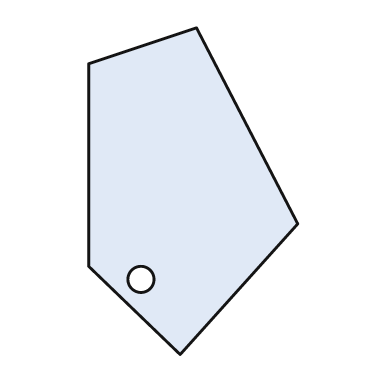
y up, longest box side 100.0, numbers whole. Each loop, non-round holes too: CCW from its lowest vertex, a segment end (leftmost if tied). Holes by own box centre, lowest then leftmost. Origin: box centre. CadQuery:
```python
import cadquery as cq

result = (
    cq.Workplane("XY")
    .moveTo(-4.0, -50.0)
    .lineTo(32.0, -10.0)
    .lineTo(1.0, 50.0)
    .lineTo(-32.0, 39.0)
    .lineTo(-32.0, -23.0)
    .close()
    .moveTo(-16.0, -27.0)
    .circle(4.0)
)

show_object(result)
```